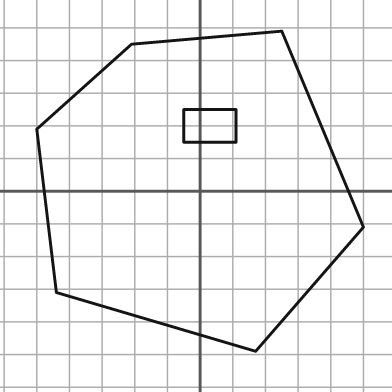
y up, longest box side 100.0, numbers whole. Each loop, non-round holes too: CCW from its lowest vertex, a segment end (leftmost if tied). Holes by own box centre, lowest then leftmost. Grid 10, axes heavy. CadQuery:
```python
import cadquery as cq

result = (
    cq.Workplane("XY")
    .moveTo(17.0, -49.0)
    .lineTo(50.0, -11.0)
    .lineTo(25.0, 49.0)
    .lineTo(-21.0, 45.0)
    .lineTo(-50.0, 19.0)
    .lineTo(-44.0, -31.0)
    .close()
    .moveTo(-5.0, 15.0)
    .lineTo(11.0, 15.0)
    .lineTo(11.0, 25.0)
    .lineTo(-5.0, 25.0)
    .close()
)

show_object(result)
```